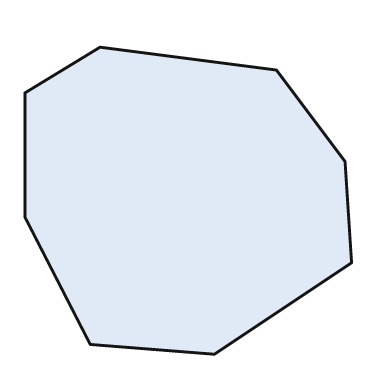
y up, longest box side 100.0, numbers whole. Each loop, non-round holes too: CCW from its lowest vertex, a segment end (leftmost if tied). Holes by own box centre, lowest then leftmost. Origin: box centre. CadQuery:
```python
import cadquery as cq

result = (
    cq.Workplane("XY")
    .moveTo(8.0, -47.0)
    .lineTo(50.0, -19.0)
    .lineTo(48.0, 12.0)
    .lineTo(27.0, 40.0)
    .lineTo(-27.0, 47.0)
    .lineTo(-50.0, 33.0)
    .lineTo(-50.0, -5.0)
    .lineTo(-30.0, -44.0)
    .close()
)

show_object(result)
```